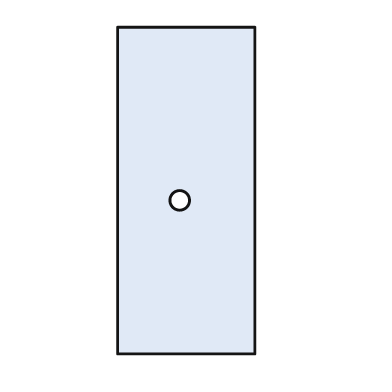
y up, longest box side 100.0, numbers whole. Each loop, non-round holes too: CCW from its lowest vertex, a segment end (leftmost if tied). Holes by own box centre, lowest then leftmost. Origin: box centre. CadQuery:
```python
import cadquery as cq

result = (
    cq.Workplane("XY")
    .moveTo(-21.0, -50.0)
    .lineTo(21.0, -50.0)
    .lineTo(21.0, 50.0)
    .lineTo(-21.0, 50.0)
    .close()
    .moveTo(-2.0, -3.0)
    .circle(3.0)
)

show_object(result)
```